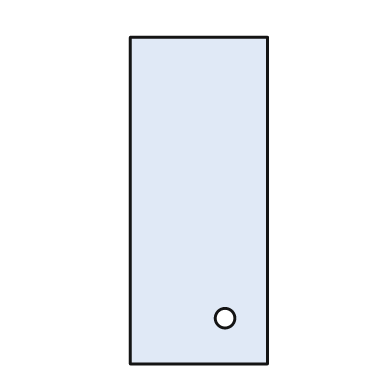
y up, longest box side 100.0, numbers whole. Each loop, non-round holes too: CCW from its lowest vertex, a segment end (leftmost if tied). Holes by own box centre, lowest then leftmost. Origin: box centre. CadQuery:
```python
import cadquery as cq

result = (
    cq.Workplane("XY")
    .moveTo(-21.0, -50.0)
    .lineTo(21.0, -50.0)
    .lineTo(21.0, 50.0)
    .lineTo(-21.0, 50.0)
    .close()
    .moveTo(8.0, -36.0)
    .circle(3.0)
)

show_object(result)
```